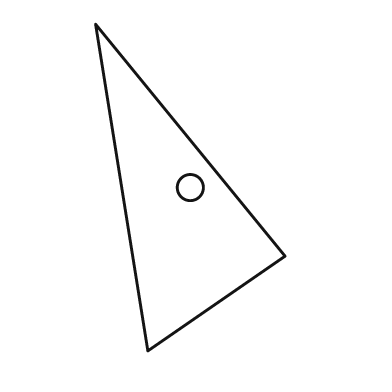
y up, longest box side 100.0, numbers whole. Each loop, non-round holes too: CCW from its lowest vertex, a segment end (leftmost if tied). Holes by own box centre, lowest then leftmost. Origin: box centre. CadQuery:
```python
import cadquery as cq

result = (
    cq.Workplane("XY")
    .moveTo(-13.0, -50.0)
    .lineTo(29.0, -21.0)
    .lineTo(-29.0, 50.0)
    .close()
    .moveTo(0.0, 0.0)
    .circle(4.0)
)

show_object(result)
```